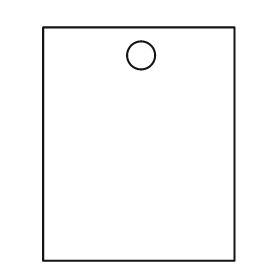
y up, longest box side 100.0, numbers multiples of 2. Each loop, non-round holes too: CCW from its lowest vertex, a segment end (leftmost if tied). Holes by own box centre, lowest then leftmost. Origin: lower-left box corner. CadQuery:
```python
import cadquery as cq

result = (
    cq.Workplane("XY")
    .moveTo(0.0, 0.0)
    .lineTo(82.0, 0.0)
    .lineTo(82.0, 100.0)
    .lineTo(0.0, 100.0)
    .close()
    .moveTo(42.0, 88.0)
    .circle(6.0)
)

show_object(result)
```